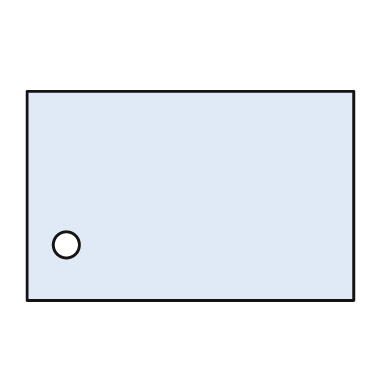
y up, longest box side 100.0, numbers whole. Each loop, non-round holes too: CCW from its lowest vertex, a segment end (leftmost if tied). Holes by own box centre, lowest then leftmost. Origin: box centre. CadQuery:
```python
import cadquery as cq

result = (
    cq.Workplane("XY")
    .moveTo(-50.0, -32.0)
    .lineTo(50.0, -32.0)
    .lineTo(50.0, 32.0)
    .lineTo(-50.0, 32.0)
    .close()
    .moveTo(-38.0, -15.0)
    .circle(4.0)
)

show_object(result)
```